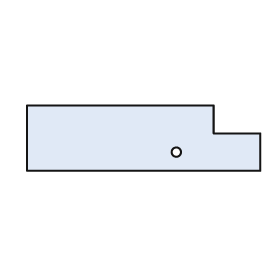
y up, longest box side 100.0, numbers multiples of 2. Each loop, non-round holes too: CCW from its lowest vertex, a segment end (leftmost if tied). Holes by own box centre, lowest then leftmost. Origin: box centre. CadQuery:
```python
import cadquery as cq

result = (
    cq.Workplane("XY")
    .moveTo(-50.0, -14.0)
    .lineTo(50.0, -14.0)
    .lineTo(50.0, 2.0)
    .lineTo(30.0, 2.0)
    .lineTo(30.0, 14.0)
    .lineTo(-50.0, 14.0)
    .close()
    .moveTo(14.0, -6.0)
    .circle(2.0)
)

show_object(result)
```